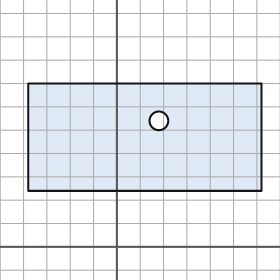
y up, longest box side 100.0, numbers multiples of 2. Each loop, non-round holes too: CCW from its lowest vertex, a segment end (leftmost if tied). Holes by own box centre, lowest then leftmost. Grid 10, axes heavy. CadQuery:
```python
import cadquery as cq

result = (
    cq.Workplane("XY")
    .moveTo(-38.0, 24.0)
    .lineTo(62.0, 24.0)
    .lineTo(62.0, 70.0)
    .lineTo(-38.0, 70.0)
    .close()
    .moveTo(18.0, 54.0)
    .circle(4.0)
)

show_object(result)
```